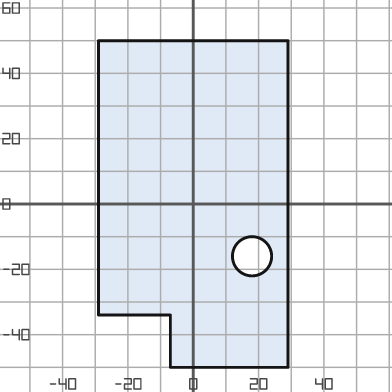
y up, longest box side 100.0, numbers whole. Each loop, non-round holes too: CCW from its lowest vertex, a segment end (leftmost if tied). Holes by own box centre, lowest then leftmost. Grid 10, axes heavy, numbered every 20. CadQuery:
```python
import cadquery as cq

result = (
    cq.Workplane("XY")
    .moveTo(-7.0, -50.0)
    .lineTo(29.0, -50.0)
    .lineTo(29.0, 50.0)
    .lineTo(-29.0, 50.0)
    .lineTo(-29.0, -34.0)
    .lineTo(-7.0, -34.0)
    .close()
    .moveTo(18.0, -16.0)
    .circle(6.0)
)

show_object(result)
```